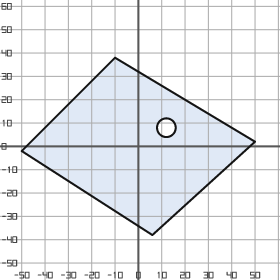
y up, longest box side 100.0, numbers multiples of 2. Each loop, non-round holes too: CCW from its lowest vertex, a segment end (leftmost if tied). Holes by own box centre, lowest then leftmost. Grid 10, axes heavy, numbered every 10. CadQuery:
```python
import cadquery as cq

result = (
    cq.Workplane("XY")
    .moveTo(6.0, -38.0)
    .lineTo(50.0, 2.0)
    .lineTo(-10.0, 38.0)
    .lineTo(-50.0, -2.0)
    .close()
    .moveTo(12.0, 8.0)
    .circle(4.0)
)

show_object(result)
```